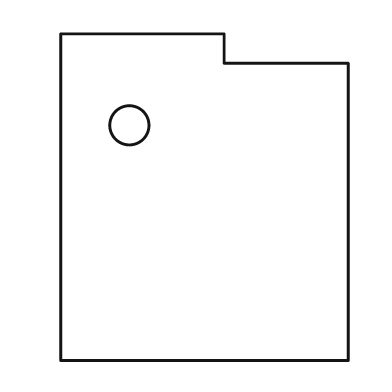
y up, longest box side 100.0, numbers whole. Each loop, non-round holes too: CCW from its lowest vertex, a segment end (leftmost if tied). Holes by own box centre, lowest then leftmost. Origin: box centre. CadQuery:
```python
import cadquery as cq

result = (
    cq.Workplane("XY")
    .moveTo(-44.0, -50.0)
    .lineTo(44.0, -50.0)
    .lineTo(44.0, 41.0)
    .lineTo(6.0, 41.0)
    .lineTo(6.0, 50.0)
    .lineTo(-44.0, 50.0)
    .close()
    .moveTo(-23.0, 22.0)
    .circle(6.0)
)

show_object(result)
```